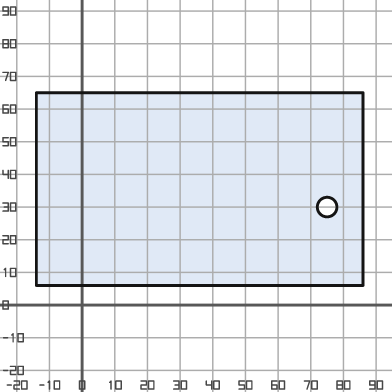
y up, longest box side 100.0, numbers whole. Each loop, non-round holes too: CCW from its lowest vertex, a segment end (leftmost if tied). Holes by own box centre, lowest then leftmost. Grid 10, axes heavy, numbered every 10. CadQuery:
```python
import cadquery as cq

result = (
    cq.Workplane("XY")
    .moveTo(-14.0, 6.0)
    .lineTo(86.0, 6.0)
    .lineTo(86.0, 65.0)
    .lineTo(-14.0, 65.0)
    .close()
    .moveTo(75.0, 30.0)
    .circle(3.0)
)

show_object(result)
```